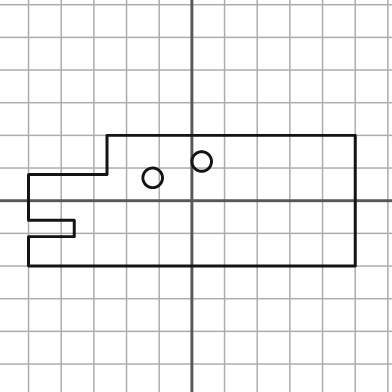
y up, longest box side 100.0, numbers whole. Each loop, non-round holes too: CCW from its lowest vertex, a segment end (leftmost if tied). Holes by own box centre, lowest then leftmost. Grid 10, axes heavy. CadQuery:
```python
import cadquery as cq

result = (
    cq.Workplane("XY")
    .moveTo(-50.0, -20.0)
    .lineTo(50.0, -20.0)
    .lineTo(50.0, 20.0)
    .lineTo(-26.0, 20.0)
    .lineTo(-26.0, 8.0)
    .lineTo(-50.0, 8.0)
    .lineTo(-50.0, -6.0)
    .lineTo(-36.0, -6.0)
    .lineTo(-36.0, -11.0)
    .lineTo(-50.0, -11.0)
    .close()
    .moveTo(-12.0, 7.0)
    .circle(3.0)
    .moveTo(3.0, 12.0)
    .circle(3.0)
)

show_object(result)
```